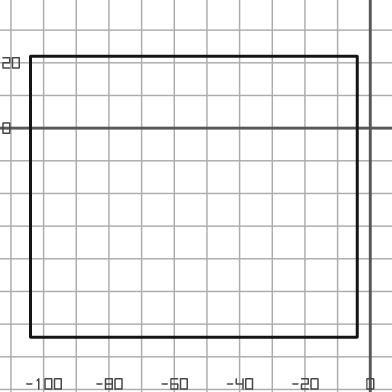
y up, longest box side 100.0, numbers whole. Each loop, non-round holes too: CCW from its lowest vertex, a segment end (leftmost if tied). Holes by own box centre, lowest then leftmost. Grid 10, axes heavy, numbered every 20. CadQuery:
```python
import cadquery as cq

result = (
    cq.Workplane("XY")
    .moveTo(-104.0, -64.0)
    .lineTo(-4.0, -64.0)
    .lineTo(-4.0, 22.0)
    .lineTo(-104.0, 22.0)
    .close()
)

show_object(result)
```